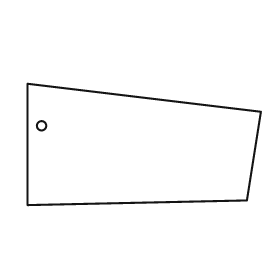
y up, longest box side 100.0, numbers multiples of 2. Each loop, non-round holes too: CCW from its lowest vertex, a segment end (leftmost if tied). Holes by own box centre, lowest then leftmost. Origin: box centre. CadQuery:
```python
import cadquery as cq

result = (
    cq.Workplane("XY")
    .moveTo(-50.0, -26.0)
    .lineTo(44.0, -24.0)
    .lineTo(50.0, 14.0)
    .lineTo(-50.0, 26.0)
    .close()
    .moveTo(-44.0, 8.0)
    .circle(2.0)
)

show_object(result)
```